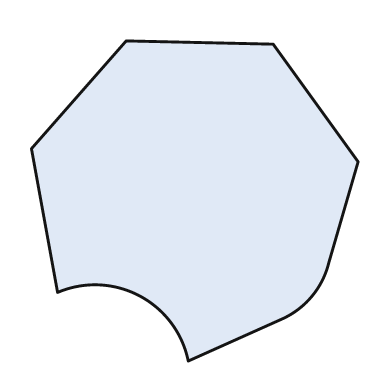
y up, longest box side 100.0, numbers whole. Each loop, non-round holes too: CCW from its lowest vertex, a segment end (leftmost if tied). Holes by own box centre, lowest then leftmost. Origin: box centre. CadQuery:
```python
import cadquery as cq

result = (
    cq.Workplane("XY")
    .moveTo(-2.0, -49.0)
    .lineTo(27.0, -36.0)
    .threePointArc((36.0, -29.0), (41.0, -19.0))
    .lineTo(50.0, 12.0)
    .lineTo(24.0, 48.0)
    .lineTo(-21.0, 49.0)
    .lineTo(-50.0, 16.0)
    .lineTo(-42.0, -28.0)
    .threePointArc((-17.0, -29.0), (-2.0, -49.0))
    .close()
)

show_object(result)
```